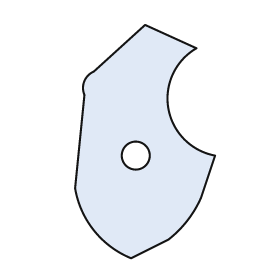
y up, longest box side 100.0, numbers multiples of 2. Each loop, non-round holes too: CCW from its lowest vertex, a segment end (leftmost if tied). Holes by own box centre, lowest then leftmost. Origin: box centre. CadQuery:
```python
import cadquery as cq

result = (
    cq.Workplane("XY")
    .moveTo(-6.0, -50.0)
    .lineTo(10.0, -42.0)
    .threePointArc((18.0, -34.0), (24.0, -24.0))
    .lineTo(30.0, -6.0)
    .threePointArc((10.0, 14.0), (22.0, 40.0))
    .lineTo(0.0, 50.0)
    .lineTo(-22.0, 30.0)
    .threePointArc((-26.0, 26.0), (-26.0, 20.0))
    .lineTo(-30.0, -20.0)
    .threePointArc((-22.0, -38.0), (-6.0, -50.0))
    .close()
    .moveTo(-4.0, -6.0)
    .circle(6.0)
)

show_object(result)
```